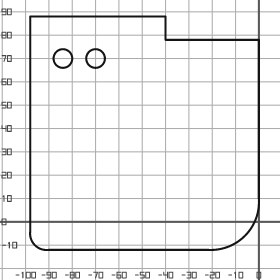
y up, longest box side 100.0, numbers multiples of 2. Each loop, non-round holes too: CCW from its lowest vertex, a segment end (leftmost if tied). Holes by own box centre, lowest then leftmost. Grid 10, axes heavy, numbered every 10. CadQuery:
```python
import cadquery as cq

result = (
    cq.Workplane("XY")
    .moveTo(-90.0, -12.0)
    .lineTo(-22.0, -12.0)
    .threePointArc((-6.0, -6.0), (0.0, 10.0))
    .lineTo(0.0, 78.0)
    .lineTo(-40.0, 78.0)
    .lineTo(-40.0, 88.0)
    .lineTo(-98.0, 88.0)
    .lineTo(-98.0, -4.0)
    .threePointArc((-96.0, -10.0), (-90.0, -12.0))
    .close()
    .moveTo(-84.0, 70.0)
    .circle(4.0)
    .moveTo(-70.0, 70.0)
    .circle(4.0)
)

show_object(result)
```